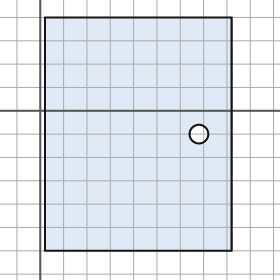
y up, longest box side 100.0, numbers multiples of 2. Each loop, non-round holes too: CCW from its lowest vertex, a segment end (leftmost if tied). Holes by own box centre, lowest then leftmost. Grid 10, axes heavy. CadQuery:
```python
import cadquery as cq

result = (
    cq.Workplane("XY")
    .moveTo(2.0, -60.0)
    .lineTo(82.0, -60.0)
    .lineTo(82.0, 40.0)
    .lineTo(2.0, 40.0)
    .close()
    .moveTo(68.0, -10.0)
    .circle(4.0)
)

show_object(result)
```